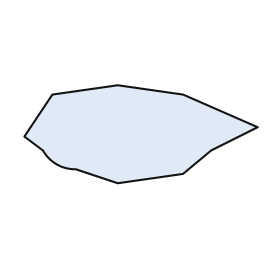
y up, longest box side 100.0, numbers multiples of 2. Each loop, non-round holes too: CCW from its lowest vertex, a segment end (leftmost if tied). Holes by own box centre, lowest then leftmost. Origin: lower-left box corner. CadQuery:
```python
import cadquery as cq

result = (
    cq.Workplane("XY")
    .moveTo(40.0, 0.0)
    .lineTo(68.0, 4.0)
    .lineTo(80.0, 14.0)
    .lineTo(100.0, 24.0)
    .lineTo(68.0, 38.0)
    .lineTo(40.0, 42.0)
    .lineTo(12.0, 38.0)
    .lineTo(0.0, 20.0)
    .lineTo(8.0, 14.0)
    .threePointArc((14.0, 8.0), (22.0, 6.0))
    .close()
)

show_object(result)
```